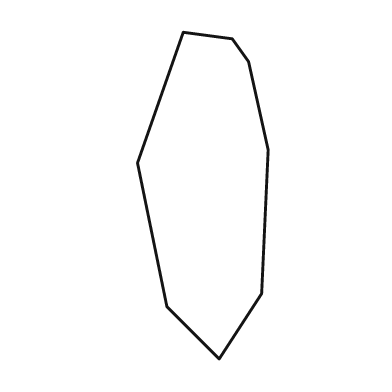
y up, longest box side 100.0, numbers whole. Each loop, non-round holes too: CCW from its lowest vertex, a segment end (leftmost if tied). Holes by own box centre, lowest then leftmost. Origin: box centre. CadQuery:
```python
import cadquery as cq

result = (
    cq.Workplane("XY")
    .moveTo(5.0, -50.0)
    .lineTo(18.0, -30.0)
    .lineTo(20.0, 14.0)
    .lineTo(14.0, 41.0)
    .lineTo(9.0, 48.0)
    .lineTo(-6.0, 50.0)
    .lineTo(-20.0, 10.0)
    .lineTo(-11.0, -34.0)
    .close()
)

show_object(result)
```